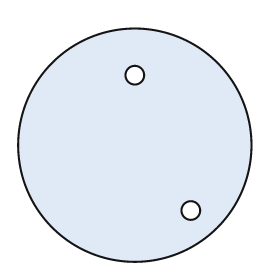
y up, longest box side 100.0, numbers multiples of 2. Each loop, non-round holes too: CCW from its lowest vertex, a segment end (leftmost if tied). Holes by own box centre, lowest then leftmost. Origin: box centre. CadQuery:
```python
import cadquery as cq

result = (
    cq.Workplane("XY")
    .moveTo(0.0, 0.0)
    .circle(50.0)
    .moveTo(24.0, -28.0)
    .circle(4.0)
    .moveTo(0.0, 30.0)
    .circle(4.0)
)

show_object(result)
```